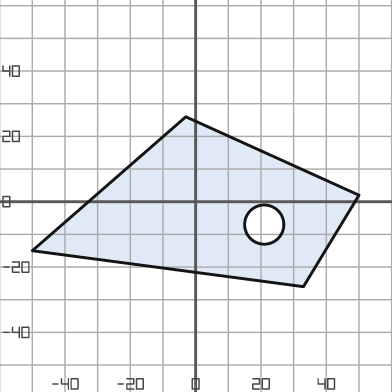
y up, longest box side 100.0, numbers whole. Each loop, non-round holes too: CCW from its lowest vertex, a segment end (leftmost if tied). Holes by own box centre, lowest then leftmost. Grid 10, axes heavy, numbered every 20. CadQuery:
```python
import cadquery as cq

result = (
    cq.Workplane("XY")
    .moveTo(33.0, -26.0)
    .lineTo(50.0, 2.0)
    .lineTo(-3.0, 26.0)
    .lineTo(-50.0, -15.0)
    .close()
    .moveTo(21.0, -7.0)
    .circle(6.0)
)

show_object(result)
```